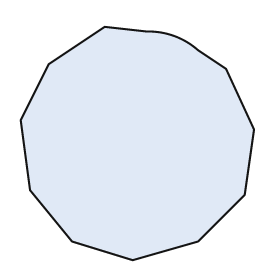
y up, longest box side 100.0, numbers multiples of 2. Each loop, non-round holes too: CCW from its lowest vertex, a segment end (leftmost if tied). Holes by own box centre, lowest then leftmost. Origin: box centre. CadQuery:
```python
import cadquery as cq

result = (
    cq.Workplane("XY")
    .moveTo(-2.0, -50.0)
    .lineTo(26.0, -42.0)
    .lineTo(46.0, -22.0)
    .lineTo(50.0, 6.0)
    .lineTo(38.0, 32.0)
    .lineTo(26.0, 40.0)
    .threePointArc((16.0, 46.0), (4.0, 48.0))
    .lineTo(-14.0, 50.0)
    .lineTo(-38.0, 34.0)
    .lineTo(-50.0, 10.0)
    .lineTo(-46.0, -20.0)
    .lineTo(-28.0, -42.0)
    .close()
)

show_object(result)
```